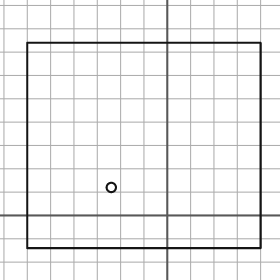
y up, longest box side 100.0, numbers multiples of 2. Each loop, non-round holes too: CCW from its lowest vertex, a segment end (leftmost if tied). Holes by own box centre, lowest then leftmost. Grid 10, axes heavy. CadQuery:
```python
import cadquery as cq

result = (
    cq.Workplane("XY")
    .moveTo(-60.0, -14.0)
    .lineTo(40.0, -14.0)
    .lineTo(40.0, 74.0)
    .lineTo(-60.0, 74.0)
    .close()
    .moveTo(-24.0, 12.0)
    .circle(2.0)
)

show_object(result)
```